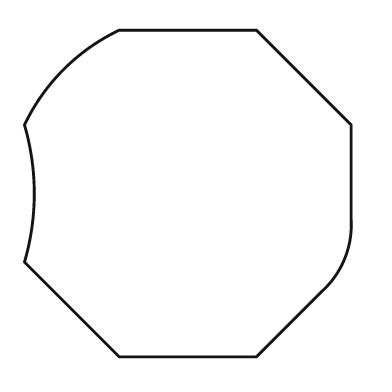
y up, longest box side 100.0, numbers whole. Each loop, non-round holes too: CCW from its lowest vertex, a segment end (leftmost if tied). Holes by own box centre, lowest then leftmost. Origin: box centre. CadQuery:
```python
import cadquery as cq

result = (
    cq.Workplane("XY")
    .moveTo(-21.0, -50.0)
    .lineTo(21.0, -50.0)
    .lineTo(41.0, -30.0)
    .threePointArc((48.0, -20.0), (50.0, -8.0))
    .lineTo(50.0, 21.0)
    .lineTo(21.0, 50.0)
    .lineTo(-21.0, 50.0)
    .threePointArc((-38.0, 38.0), (-50.0, 21.0))
    .threePointArc((-47.0, 0.0), (-50.0, -21.0))
    .close()
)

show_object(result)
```